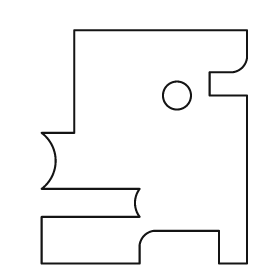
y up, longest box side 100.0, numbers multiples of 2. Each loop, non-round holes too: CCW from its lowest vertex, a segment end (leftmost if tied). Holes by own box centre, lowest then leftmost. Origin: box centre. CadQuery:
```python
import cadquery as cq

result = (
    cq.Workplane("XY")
    .moveTo(-44.0, -50.0)
    .lineTo(-2.0, -50.0)
    .lineTo(-2.0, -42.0)
    .threePointArc((0.0, -38.0), (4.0, -36.0))
    .lineTo(32.0, -36.0)
    .lineTo(32.0, -50.0)
    .lineTo(44.0, -50.0)
    .lineTo(44.0, 22.0)
    .lineTo(28.0, 22.0)
    .lineTo(28.0, 32.0)
    .lineTo(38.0, 32.0)
    .threePointArc((42.0, 34.0), (44.0, 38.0))
    .lineTo(44.0, 50.0)
    .lineTo(-30.0, 50.0)
    .lineTo(-30.0, 6.0)
    .lineTo(-44.0, 6.0)
    .threePointArc((-38.0, -6.0), (-44.0, -18.0))
    .lineTo(-2.0, -18.0)
    .threePointArc((-4.0, -24.0), (-2.0, -30.0))
    .lineTo(-44.0, -30.0)
    .close()
    .moveTo(14.0, 22.0)
    .circle(6.0)
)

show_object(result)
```